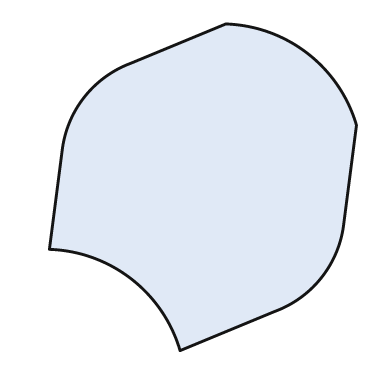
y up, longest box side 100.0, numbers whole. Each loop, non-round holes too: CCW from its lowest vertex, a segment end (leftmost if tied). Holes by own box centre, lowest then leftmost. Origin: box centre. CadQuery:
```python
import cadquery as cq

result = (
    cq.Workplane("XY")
    .moveTo(-7.0, -50.0)
    .lineTo(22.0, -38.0)
    .threePointArc((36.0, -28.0), (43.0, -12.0))
    .lineTo(47.0, 19.0)
    .threePointArc((32.0, 41.0), (7.0, 50.0))
    .lineTo(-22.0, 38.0)
    .threePointArc((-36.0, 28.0), (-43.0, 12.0))
    .lineTo(-47.0, -19.0)
    .threePointArc((-22.0, -28.0), (-7.0, -50.0))
    .close()
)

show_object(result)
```